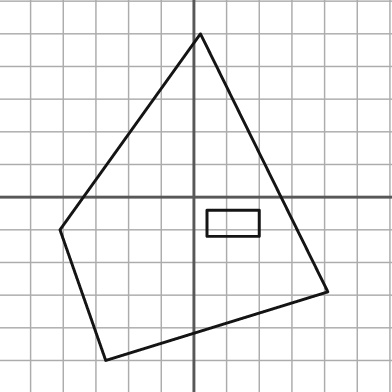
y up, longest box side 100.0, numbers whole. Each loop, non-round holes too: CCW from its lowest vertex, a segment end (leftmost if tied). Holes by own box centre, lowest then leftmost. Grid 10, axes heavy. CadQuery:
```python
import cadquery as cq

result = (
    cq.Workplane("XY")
    .moveTo(-27.0, -50.0)
    .lineTo(41.0, -29.0)
    .lineTo(2.0, 50.0)
    .lineTo(-41.0, -10.0)
    .close()
    .moveTo(4.0, -12.0)
    .lineTo(20.0, -12.0)
    .lineTo(20.0, -4.0)
    .lineTo(4.0, -4.0)
    .close()
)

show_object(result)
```